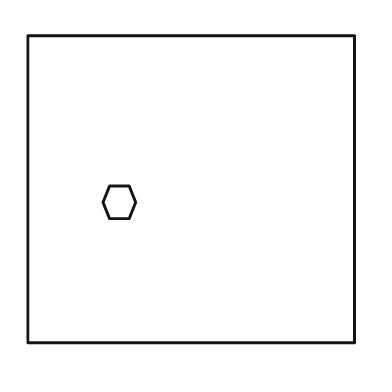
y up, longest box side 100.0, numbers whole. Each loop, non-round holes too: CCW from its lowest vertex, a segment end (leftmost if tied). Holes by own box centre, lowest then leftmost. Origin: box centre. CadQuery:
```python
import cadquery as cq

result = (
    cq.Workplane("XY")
    .moveTo(-50.0, -47.0)
    .lineTo(50.0, -47.0)
    .lineTo(50.0, 47.0)
    .lineTo(-50.0, 47.0)
    .close()
    .moveTo(-25.0, -9.0)
    .lineTo(-19.0, -9.0)
    .lineTo(-17.0, -4.0)
    .lineTo(-19.0, 1.0)
    .lineTo(-25.0, 1.0)
    .lineTo(-27.0, -4.0)
    .close()
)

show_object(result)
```